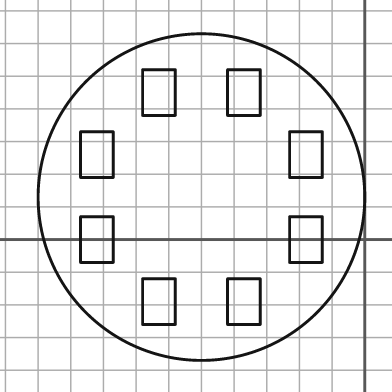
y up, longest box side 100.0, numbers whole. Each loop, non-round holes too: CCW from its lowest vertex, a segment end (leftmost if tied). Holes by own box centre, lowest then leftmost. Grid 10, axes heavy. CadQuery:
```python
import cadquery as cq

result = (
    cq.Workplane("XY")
    .moveTo(-50.0, 13.0)
    .circle(50.0)
    .moveTo(-68.0, -26.0)
    .lineTo(-58.0, -26.0)
    .lineTo(-58.0, -12.0)
    .lineTo(-68.0, -12.0)
    .close()
    .moveTo(-42.0, -26.0)
    .lineTo(-32.0, -26.0)
    .lineTo(-32.0, -12.0)
    .lineTo(-42.0, -12.0)
    .close()
    .moveTo(-87.0, -7.0)
    .lineTo(-77.0, -7.0)
    .lineTo(-77.0, 7.0)
    .lineTo(-87.0, 7.0)
    .close()
    .moveTo(-23.0, -7.0)
    .lineTo(-13.0, -7.0)
    .lineTo(-13.0, 7.0)
    .lineTo(-23.0, 7.0)
    .close()
    .moveTo(-87.0, 19.0)
    .lineTo(-77.0, 19.0)
    .lineTo(-77.0, 33.0)
    .lineTo(-87.0, 33.0)
    .close()
    .moveTo(-23.0, 19.0)
    .lineTo(-13.0, 19.0)
    .lineTo(-13.0, 33.0)
    .lineTo(-23.0, 33.0)
    .close()
    .moveTo(-68.0, 38.0)
    .lineTo(-58.0, 38.0)
    .lineTo(-58.0, 52.0)
    .lineTo(-68.0, 52.0)
    .close()
    .moveTo(-42.0, 38.0)
    .lineTo(-32.0, 38.0)
    .lineTo(-32.0, 52.0)
    .lineTo(-42.0, 52.0)
    .close()
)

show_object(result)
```